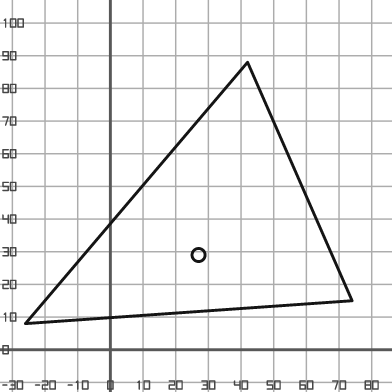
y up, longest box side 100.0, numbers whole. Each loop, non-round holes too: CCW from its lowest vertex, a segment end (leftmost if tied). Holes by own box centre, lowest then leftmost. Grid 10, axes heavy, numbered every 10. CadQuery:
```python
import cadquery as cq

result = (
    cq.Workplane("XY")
    .moveTo(-26.0, 8.0)
    .lineTo(74.0, 15.0)
    .lineTo(42.0, 88.0)
    .close()
    .moveTo(27.0, 29.0)
    .circle(2.0)
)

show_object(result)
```